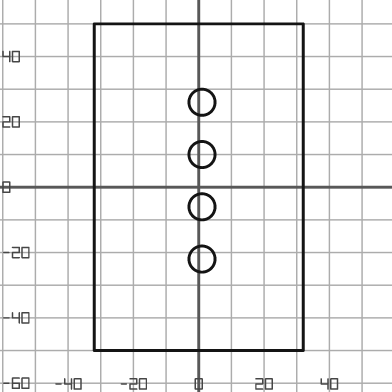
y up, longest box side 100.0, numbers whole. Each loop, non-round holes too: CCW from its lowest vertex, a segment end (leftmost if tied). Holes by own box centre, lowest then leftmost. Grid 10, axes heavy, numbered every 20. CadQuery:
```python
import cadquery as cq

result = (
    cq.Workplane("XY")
    .moveTo(-32.0, -50.0)
    .lineTo(32.0, -50.0)
    .lineTo(32.0, 50.0)
    .lineTo(-32.0, 50.0)
    .close()
    .moveTo(1.0, -22.0)
    .circle(4.0)
    .moveTo(1.0, -6.0)
    .circle(4.0)
    .moveTo(1.0, 10.0)
    .circle(4.0)
    .moveTo(1.0, 26.0)
    .circle(4.0)
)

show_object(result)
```